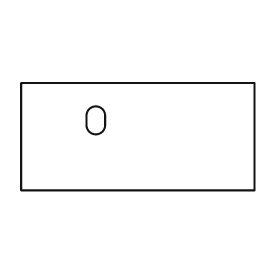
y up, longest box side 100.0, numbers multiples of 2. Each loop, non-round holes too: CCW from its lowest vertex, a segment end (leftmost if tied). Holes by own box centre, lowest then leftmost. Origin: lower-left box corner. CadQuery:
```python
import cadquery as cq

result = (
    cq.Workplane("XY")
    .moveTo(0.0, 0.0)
    .lineTo(100.0, 0.0)
    .lineTo(100.0, 46.0)
    .lineTo(0.0, 46.0)
    .close()
    .moveTo(28.0, 28.0)
    .threePointArc((32.0, 24.0), (36.0, 28.0))
    .lineTo(36.0, 32.0)
    .threePointArc((32.0, 36.0), (28.0, 32.0))
    .close()
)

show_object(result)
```